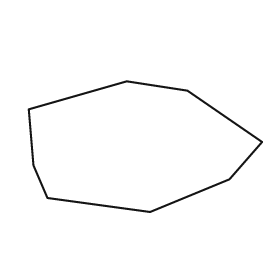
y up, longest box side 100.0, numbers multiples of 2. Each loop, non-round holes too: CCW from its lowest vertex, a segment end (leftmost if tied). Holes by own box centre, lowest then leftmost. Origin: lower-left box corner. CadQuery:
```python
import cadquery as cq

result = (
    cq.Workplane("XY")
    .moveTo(52.0, 0.0)
    .lineTo(86.0, 14.0)
    .lineTo(100.0, 30.0)
    .lineTo(68.0, 52.0)
    .lineTo(42.0, 56.0)
    .lineTo(0.0, 44.0)
    .lineTo(2.0, 20.0)
    .lineTo(8.0, 6.0)
    .close()
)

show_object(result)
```